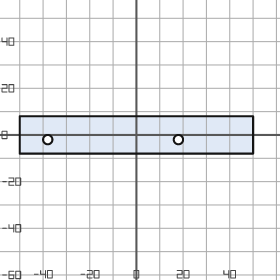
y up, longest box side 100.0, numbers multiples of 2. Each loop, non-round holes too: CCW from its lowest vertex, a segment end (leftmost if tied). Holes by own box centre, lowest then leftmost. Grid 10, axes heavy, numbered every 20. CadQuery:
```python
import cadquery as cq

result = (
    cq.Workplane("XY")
    .moveTo(-50.0, -8.0)
    .lineTo(50.0, -8.0)
    .lineTo(50.0, 8.0)
    .lineTo(-50.0, 8.0)
    .close()
    .moveTo(-38.0, -2.0)
    .circle(2.0)
    .moveTo(18.0, -2.0)
    .circle(2.0)
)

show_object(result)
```